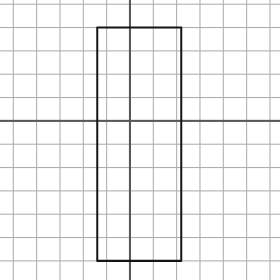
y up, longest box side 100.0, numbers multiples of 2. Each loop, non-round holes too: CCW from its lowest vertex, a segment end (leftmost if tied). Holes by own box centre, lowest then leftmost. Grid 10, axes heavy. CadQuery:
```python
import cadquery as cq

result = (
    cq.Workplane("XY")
    .moveTo(-14.0, -60.0)
    .lineTo(22.0, -60.0)
    .lineTo(22.0, 40.0)
    .lineTo(-14.0, 40.0)
    .close()
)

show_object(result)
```